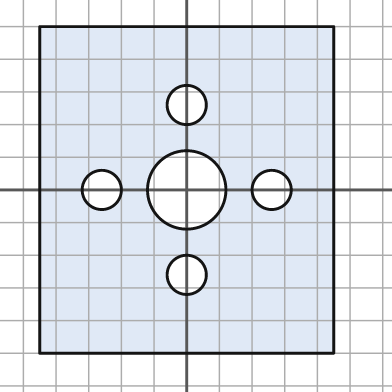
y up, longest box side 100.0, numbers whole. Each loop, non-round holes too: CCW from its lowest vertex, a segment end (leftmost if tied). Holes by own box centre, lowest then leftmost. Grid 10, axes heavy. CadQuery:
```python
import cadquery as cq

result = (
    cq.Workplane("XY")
    .moveTo(-45.0, -50.0)
    .lineTo(45.0, -50.0)
    .lineTo(45.0, 50.0)
    .lineTo(-45.0, 50.0)
    .close()
    .moveTo(0.0, -26.0)
    .circle(6.0)
    .moveTo(-26.0, 0.0)
    .circle(6.0)
    .moveTo(0.0, 0.0)
    .circle(12.0)
    .moveTo(26.0, 0.0)
    .circle(6.0)
    .moveTo(0.0, 26.0)
    .circle(6.0)
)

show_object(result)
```